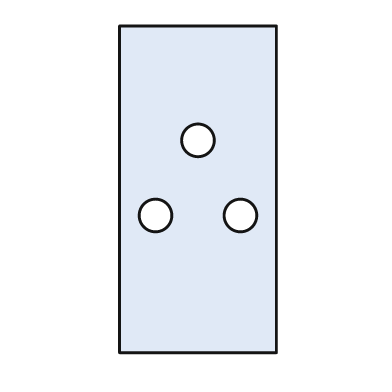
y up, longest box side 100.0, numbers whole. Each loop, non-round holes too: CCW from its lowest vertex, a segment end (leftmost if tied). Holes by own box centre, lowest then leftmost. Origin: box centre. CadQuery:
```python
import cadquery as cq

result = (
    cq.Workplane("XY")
    .moveTo(-24.0, -50.0)
    .lineTo(24.0, -50.0)
    .lineTo(24.0, 50.0)
    .lineTo(-24.0, 50.0)
    .close()
    .moveTo(-13.0, -8.0)
    .circle(5.0)
    .moveTo(13.0, -8.0)
    .circle(5.0)
    .moveTo(0.0, 15.0)
    .circle(5.0)
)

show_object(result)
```